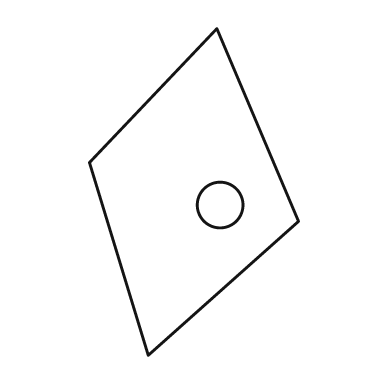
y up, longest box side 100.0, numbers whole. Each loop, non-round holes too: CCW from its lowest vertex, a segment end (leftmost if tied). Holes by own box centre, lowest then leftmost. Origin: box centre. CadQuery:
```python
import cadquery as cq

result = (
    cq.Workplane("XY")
    .moveTo(-14.0, -50.0)
    .lineTo(32.0, -9.0)
    .lineTo(7.0, 50.0)
    .lineTo(-32.0, 9.0)
    .close()
    .moveTo(8.0, -4.0)
    .circle(7.0)
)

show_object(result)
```